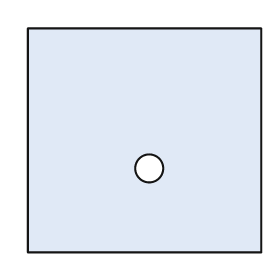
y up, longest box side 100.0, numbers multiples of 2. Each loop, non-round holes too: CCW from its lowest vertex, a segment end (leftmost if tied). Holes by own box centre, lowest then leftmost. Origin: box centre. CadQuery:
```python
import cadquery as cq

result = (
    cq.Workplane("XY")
    .moveTo(-50.0, -48.0)
    .lineTo(50.0, -48.0)
    .lineTo(50.0, 48.0)
    .lineTo(-50.0, 48.0)
    .close()
    .moveTo(2.0, -12.0)
    .circle(6.0)
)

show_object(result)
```